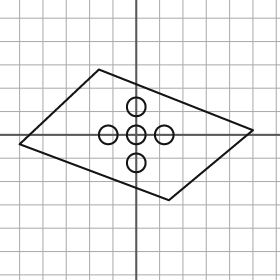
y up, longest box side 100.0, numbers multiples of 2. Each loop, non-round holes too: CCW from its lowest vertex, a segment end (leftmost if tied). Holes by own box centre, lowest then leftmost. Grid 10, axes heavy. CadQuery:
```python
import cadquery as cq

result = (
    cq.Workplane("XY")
    .moveTo(14.0, -28.0)
    .lineTo(50.0, 2.0)
    .lineTo(-16.0, 28.0)
    .lineTo(-50.0, -4.0)
    .close()
    .moveTo(0.0, -12.0)
    .circle(4.0)
    .moveTo(-12.0, 0.0)
    .circle(4.0)
    .moveTo(0.0, 0.0)
    .circle(4.0)
    .moveTo(12.0, 0.0)
    .circle(4.0)
    .moveTo(0.0, 12.0)
    .circle(4.0)
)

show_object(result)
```